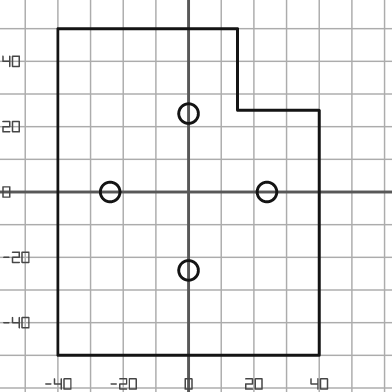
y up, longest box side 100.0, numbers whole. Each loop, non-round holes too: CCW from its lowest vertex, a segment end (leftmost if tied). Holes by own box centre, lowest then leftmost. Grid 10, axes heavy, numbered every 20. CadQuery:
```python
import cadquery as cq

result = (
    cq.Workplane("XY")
    .moveTo(-40.0, -50.0)
    .lineTo(40.0, -50.0)
    .lineTo(40.0, 25.0)
    .lineTo(15.0, 25.0)
    .lineTo(15.0, 50.0)
    .lineTo(-40.0, 50.0)
    .close()
    .moveTo(0.0, -24.0)
    .circle(3.0)
    .moveTo(-24.0, 0.0)
    .circle(3.0)
    .moveTo(24.0, 0.0)
    .circle(3.0)
    .moveTo(0.0, 24.0)
    .circle(3.0)
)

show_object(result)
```